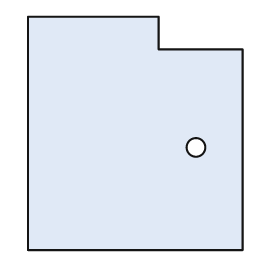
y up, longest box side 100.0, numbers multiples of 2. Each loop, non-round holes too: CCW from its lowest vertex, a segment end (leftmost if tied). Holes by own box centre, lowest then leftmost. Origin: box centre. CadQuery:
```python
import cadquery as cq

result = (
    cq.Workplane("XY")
    .moveTo(-46.0, -50.0)
    .lineTo(46.0, -50.0)
    .lineTo(46.0, 36.0)
    .lineTo(10.0, 36.0)
    .lineTo(10.0, 50.0)
    .lineTo(-46.0, 50.0)
    .close()
    .moveTo(26.0, -6.0)
    .circle(4.0)
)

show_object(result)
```